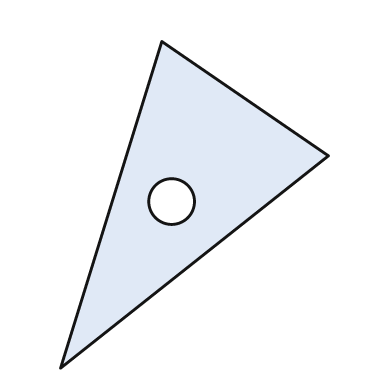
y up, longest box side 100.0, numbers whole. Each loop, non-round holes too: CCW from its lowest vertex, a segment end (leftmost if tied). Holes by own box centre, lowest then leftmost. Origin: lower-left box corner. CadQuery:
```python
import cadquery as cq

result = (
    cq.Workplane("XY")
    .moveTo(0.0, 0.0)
    .lineTo(82.0, 65.0)
    .lineTo(31.0, 100.0)
    .close()
    .moveTo(34.0, 51.0)
    .circle(7.0)
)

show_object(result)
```